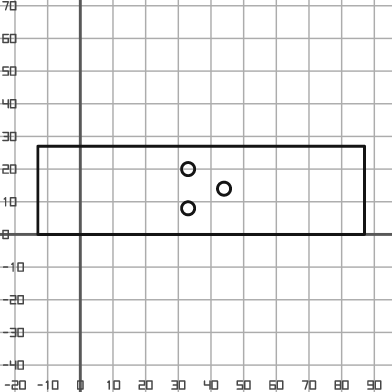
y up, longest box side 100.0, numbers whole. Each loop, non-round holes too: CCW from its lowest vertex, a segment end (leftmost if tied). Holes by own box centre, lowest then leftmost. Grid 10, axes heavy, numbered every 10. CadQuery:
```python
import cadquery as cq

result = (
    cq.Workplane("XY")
    .moveTo(-13.0, 0.0)
    .lineTo(87.0, 0.0)
    .lineTo(87.0, 27.0)
    .lineTo(-13.0, 27.0)
    .close()
    .moveTo(33.0, 8.0)
    .circle(2.0)
    .moveTo(44.0, 14.0)
    .circle(2.0)
    .moveTo(33.0, 20.0)
    .circle(2.0)
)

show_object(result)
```